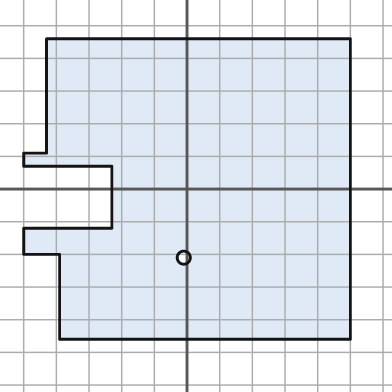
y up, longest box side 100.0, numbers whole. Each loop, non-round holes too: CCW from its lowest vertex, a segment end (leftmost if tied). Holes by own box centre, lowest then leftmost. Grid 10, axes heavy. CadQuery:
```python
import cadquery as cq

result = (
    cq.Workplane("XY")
    .moveTo(-39.0, -46.0)
    .lineTo(50.0, -46.0)
    .lineTo(50.0, 46.0)
    .lineTo(-43.0, 46.0)
    .lineTo(-43.0, 11.0)
    .lineTo(-50.0, 11.0)
    .lineTo(-50.0, 7.0)
    .lineTo(-23.0, 7.0)
    .lineTo(-23.0, -12.0)
    .lineTo(-50.0, -12.0)
    .lineTo(-50.0, -20.0)
    .lineTo(-39.0, -20.0)
    .close()
    .moveTo(-1.0, -21.0)
    .circle(2.0)
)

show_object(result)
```